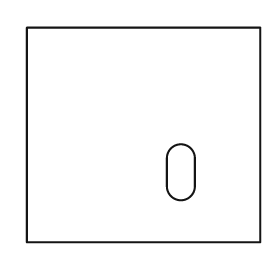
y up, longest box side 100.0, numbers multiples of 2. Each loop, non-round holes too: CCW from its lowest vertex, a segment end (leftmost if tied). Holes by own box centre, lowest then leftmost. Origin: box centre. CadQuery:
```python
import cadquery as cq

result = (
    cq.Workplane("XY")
    .moveTo(-50.0, -46.0)
    .lineTo(50.0, -46.0)
    .lineTo(50.0, 46.0)
    .lineTo(-50.0, 46.0)
    .close()
    .moveTo(10.0, -22.0)
    .threePointArc((16.0, -28.0), (22.0, -22.0))
    .lineTo(22.0, -10.0)
    .threePointArc((16.0, -4.0), (10.0, -10.0))
    .close()
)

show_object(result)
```